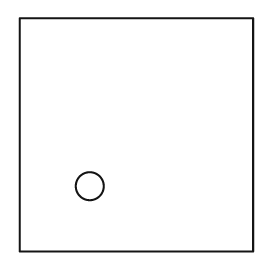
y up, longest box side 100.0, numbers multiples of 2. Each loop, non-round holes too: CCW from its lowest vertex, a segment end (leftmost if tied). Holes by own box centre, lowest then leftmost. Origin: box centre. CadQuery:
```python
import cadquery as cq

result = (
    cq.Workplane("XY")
    .moveTo(-50.0, -50.0)
    .lineTo(50.0, -50.0)
    .lineTo(50.0, 50.0)
    .lineTo(-50.0, 50.0)
    .close()
    .moveTo(-20.0, -22.0)
    .circle(6.0)
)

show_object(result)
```